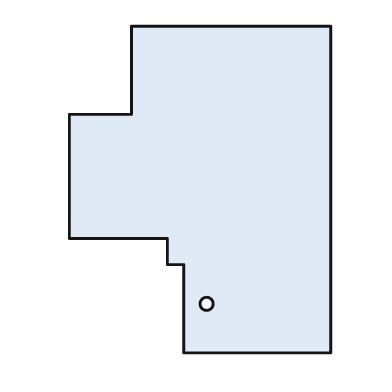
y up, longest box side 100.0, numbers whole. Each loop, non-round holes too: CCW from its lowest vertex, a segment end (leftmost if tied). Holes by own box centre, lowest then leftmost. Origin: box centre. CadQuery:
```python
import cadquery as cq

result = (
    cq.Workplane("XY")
    .moveTo(-5.0, -50.0)
    .lineTo(40.0, -50.0)
    .lineTo(40.0, 50.0)
    .lineTo(-21.0, 50.0)
    .lineTo(-21.0, 23.0)
    .lineTo(-40.0, 23.0)
    .lineTo(-40.0, -15.0)
    .lineTo(-10.0, -15.0)
    .lineTo(-10.0, -23.0)
    .lineTo(-5.0, -23.0)
    .close()
    .moveTo(2.0, -35.0)
    .circle(2.0)
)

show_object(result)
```